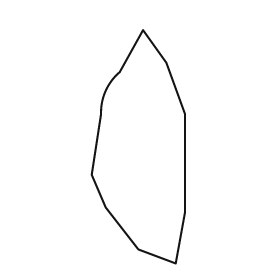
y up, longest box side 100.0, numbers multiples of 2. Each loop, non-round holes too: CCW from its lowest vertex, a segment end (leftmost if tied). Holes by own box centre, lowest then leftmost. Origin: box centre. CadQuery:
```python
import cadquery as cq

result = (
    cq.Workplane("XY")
    .moveTo(16.0, -50.0)
    .lineTo(20.0, -28.0)
    .lineTo(20.0, 14.0)
    .lineTo(12.0, 36.0)
    .lineTo(2.0, 50.0)
    .lineTo(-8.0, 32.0)
    .threePointArc((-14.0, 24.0), (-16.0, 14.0))
    .lineTo(-20.0, -12.0)
    .lineTo(-14.0, -26.0)
    .lineTo(0.0, -44.0)
    .close()
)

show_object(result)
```